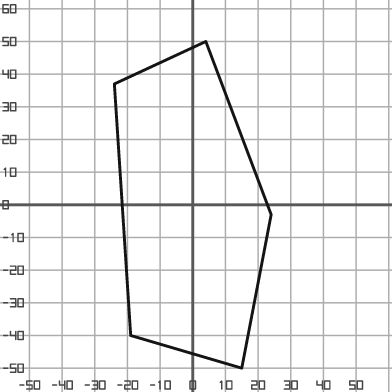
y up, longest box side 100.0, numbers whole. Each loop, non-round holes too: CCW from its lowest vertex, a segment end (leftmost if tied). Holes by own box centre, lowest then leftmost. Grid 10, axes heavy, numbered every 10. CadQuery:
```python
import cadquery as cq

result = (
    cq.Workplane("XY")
    .moveTo(15.0, -50.0)
    .lineTo(24.0, -3.0)
    .lineTo(4.0, 50.0)
    .lineTo(-24.0, 37.0)
    .lineTo(-19.0, -40.0)
    .close()
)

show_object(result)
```